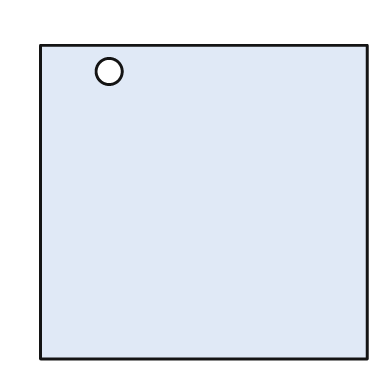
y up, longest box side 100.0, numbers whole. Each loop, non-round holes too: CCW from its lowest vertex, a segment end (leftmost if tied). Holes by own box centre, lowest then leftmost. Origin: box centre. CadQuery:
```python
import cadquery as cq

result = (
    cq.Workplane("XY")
    .moveTo(-50.0, -48.0)
    .lineTo(50.0, -48.0)
    .lineTo(50.0, 48.0)
    .lineTo(-50.0, 48.0)
    .close()
    .moveTo(-29.0, 40.0)
    .circle(4.0)
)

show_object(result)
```